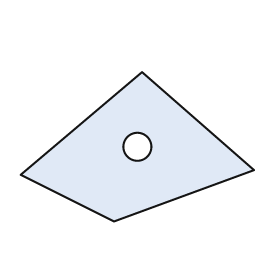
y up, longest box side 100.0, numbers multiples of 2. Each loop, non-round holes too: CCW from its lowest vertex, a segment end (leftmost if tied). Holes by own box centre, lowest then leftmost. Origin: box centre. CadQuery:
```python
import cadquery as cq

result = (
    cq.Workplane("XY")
    .moveTo(-10.0, -32.0)
    .lineTo(50.0, -10.0)
    .lineTo(2.0, 32.0)
    .lineTo(-50.0, -12.0)
    .close()
    .moveTo(0.0, 0.0)
    .circle(6.0)
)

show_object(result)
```